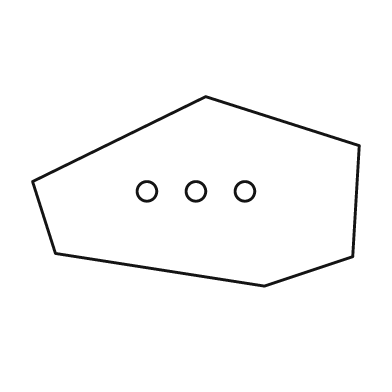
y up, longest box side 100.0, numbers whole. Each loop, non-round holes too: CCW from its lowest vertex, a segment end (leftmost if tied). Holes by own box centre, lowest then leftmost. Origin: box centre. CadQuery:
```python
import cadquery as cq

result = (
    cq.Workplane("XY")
    .moveTo(21.0, -29.0)
    .lineTo(48.0, -20.0)
    .lineTo(50.0, 14.0)
    .lineTo(3.0, 29.0)
    .lineTo(-50.0, 3.0)
    .lineTo(-43.0, -19.0)
    .close()
    .moveTo(-15.0, 0.0)
    .circle(3.0)
    .moveTo(0.0, 0.0)
    .circle(3.0)
    .moveTo(15.0, 0.0)
    .circle(3.0)
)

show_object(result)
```